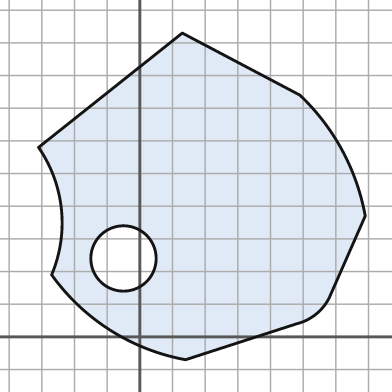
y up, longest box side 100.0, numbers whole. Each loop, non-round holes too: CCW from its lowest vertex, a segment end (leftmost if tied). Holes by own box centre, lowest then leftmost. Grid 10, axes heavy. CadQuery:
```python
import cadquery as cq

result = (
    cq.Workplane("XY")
    .moveTo(14.0, -7.0)
    .lineTo(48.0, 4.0)
    .threePointArc((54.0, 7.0), (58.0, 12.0))
    .lineTo(69.0, 37.0)
    .threePointArc((62.0, 57.0), (49.0, 74.0))
    .lineTo(13.0, 93.0)
    .lineTo(-31.0, 58.0)
    .threePointArc((-24.0, 39.0), (-27.0, 19.0))
    .threePointArc((-9.0, 2.0), (14.0, -7.0))
    .close()
    .moveTo(-5.0, 24.0)
    .circle(10.0)
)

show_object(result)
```